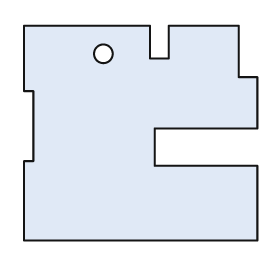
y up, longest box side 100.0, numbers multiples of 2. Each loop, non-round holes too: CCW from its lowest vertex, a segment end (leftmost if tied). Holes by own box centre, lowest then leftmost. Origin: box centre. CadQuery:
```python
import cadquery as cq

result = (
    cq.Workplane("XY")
    .moveTo(-50.0, -46.0)
    .lineTo(50.0, -46.0)
    .lineTo(50.0, -14.0)
    .lineTo(6.0, -14.0)
    .lineTo(6.0, 2.0)
    .lineTo(50.0, 2.0)
    .lineTo(50.0, 24.0)
    .lineTo(42.0, 24.0)
    .lineTo(42.0, 46.0)
    .lineTo(12.0, 46.0)
    .lineTo(12.0, 32.0)
    .lineTo(4.0, 32.0)
    .lineTo(4.0, 46.0)
    .lineTo(-50.0, 46.0)
    .lineTo(-50.0, 18.0)
    .lineTo(-46.0, 18.0)
    .lineTo(-46.0, -12.0)
    .lineTo(-50.0, -12.0)
    .close()
    .moveTo(-16.0, 34.0)
    .circle(4.0)
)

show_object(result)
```